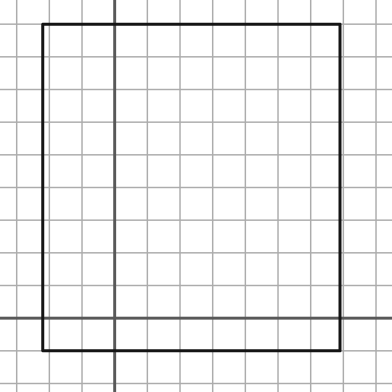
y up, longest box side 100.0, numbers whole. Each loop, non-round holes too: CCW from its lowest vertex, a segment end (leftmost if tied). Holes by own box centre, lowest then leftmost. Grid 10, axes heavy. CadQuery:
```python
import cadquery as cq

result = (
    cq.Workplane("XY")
    .moveTo(-22.0, -10.0)
    .lineTo(69.0, -10.0)
    .lineTo(69.0, 90.0)
    .lineTo(-22.0, 90.0)
    .close()
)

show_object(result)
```